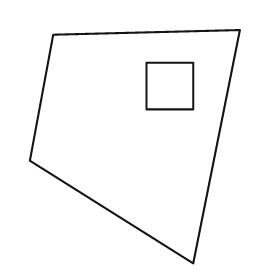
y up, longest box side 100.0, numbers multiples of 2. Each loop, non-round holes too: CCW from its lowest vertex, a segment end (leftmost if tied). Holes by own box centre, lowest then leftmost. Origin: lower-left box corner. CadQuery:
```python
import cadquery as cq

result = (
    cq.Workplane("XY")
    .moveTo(70.0, 0.0)
    .lineTo(90.0, 100.0)
    .lineTo(10.0, 98.0)
    .lineTo(0.0, 44.0)
    .close()
    .moveTo(50.0, 66.0)
    .lineTo(70.0, 66.0)
    .lineTo(70.0, 86.0)
    .lineTo(50.0, 86.0)
    .close()
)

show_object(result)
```